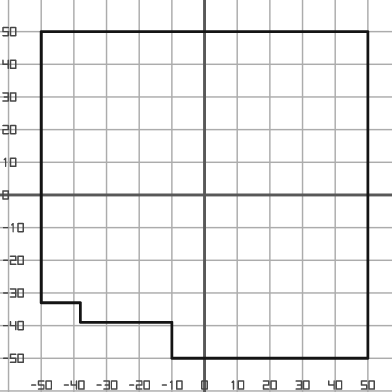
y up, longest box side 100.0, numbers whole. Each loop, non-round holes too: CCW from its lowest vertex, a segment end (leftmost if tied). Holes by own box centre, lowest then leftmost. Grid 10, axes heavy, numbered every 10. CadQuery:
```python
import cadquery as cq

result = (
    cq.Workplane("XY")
    .moveTo(-10.0, -50.0)
    .lineTo(50.0, -50.0)
    .lineTo(50.0, 50.0)
    .lineTo(-50.0, 50.0)
    .lineTo(-50.0, -33.0)
    .lineTo(-38.0, -33.0)
    .lineTo(-38.0, -39.0)
    .lineTo(-10.0, -39.0)
    .close()
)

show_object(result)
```